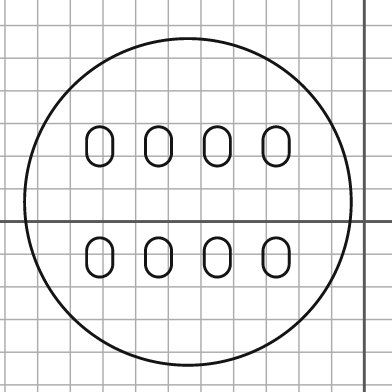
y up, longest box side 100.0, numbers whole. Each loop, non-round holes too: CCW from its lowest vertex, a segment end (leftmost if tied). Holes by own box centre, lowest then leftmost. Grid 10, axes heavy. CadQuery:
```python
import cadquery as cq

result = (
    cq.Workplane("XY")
    .moveTo(-54.0, 6.0)
    .circle(50.0)
    .moveTo(-85.0, -13.0)
    .threePointArc((-81.0, -17.0), (-77.0, -13.0))
    .lineTo(-77.0, -9.0)
    .threePointArc((-81.0, -5.0), (-85.0, -9.0))
    .close()
    .moveTo(-67.0, -13.0)
    .threePointArc((-63.0, -17.0), (-59.0, -13.0))
    .lineTo(-59.0, -9.0)
    .threePointArc((-63.0, -5.0), (-67.0, -9.0))
    .close()
    .moveTo(-49.0, -13.0)
    .threePointArc((-45.0, -17.0), (-41.0, -13.0))
    .lineTo(-41.0, -9.0)
    .threePointArc((-45.0, -5.0), (-49.0, -9.0))
    .close()
    .moveTo(-31.0, -13.0)
    .threePointArc((-27.0, -17.0), (-23.0, -13.0))
    .lineTo(-23.0, -9.0)
    .threePointArc((-27.0, -5.0), (-31.0, -9.0))
    .close()
    .moveTo(-85.0, 21.0)
    .threePointArc((-81.0, 17.0), (-77.0, 21.0))
    .lineTo(-77.0, 25.0)
    .threePointArc((-81.0, 29.0), (-85.0, 25.0))
    .close()
    .moveTo(-67.0, 21.0)
    .threePointArc((-63.0, 17.0), (-59.0, 21.0))
    .lineTo(-59.0, 25.0)
    .threePointArc((-63.0, 29.0), (-67.0, 25.0))
    .close()
    .moveTo(-49.0, 21.0)
    .threePointArc((-45.0, 17.0), (-41.0, 21.0))
    .lineTo(-41.0, 25.0)
    .threePointArc((-45.0, 29.0), (-49.0, 25.0))
    .close()
    .moveTo(-31.0, 21.0)
    .threePointArc((-27.0, 17.0), (-23.0, 21.0))
    .lineTo(-23.0, 25.0)
    .threePointArc((-27.0, 29.0), (-31.0, 25.0))
    .close()
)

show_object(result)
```